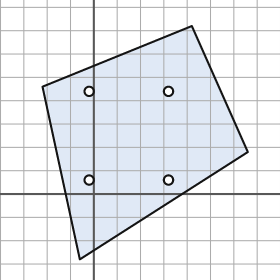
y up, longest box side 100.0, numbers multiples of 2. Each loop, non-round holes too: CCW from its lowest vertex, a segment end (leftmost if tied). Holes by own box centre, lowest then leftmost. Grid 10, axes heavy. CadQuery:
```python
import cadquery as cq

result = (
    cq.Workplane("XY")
    .moveTo(-6.0, -28.0)
    .lineTo(66.0, 18.0)
    .lineTo(42.0, 72.0)
    .lineTo(-22.0, 46.0)
    .close()
    .moveTo(-2.0, 6.0)
    .circle(2.0)
    .moveTo(32.0, 6.0)
    .circle(2.0)
    .moveTo(-2.0, 44.0)
    .circle(2.0)
    .moveTo(32.0, 44.0)
    .circle(2.0)
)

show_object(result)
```